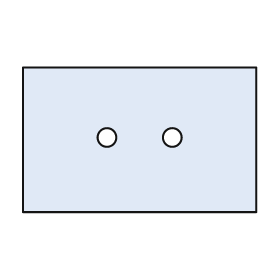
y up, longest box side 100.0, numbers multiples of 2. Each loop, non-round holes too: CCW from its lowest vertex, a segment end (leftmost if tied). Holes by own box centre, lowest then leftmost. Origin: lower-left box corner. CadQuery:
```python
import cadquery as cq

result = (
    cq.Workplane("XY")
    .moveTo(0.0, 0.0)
    .lineTo(100.0, 0.0)
    .lineTo(100.0, 62.0)
    .lineTo(0.0, 62.0)
    .close()
    .moveTo(36.0, 32.0)
    .circle(4.0)
    .moveTo(64.0, 32.0)
    .circle(4.0)
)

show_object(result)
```